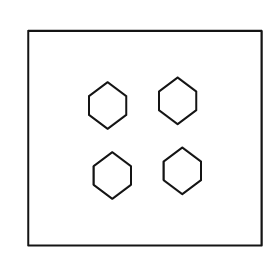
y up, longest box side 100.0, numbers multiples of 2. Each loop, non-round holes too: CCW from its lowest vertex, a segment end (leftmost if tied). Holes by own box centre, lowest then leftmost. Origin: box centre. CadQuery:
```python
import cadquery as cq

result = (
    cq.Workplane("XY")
    .moveTo(-50.0, -46.0)
    .lineTo(50.0, -46.0)
    .lineTo(50.0, 46.0)
    .lineTo(-50.0, 46.0)
    .close()
    .moveTo(-14.0, -26.0)
    .lineTo(-6.0, -20.0)
    .lineTo(-6.0, -12.0)
    .lineTo(-14.0, -6.0)
    .lineTo(-22.0, -12.0)
    .lineTo(-22.0, -20.0)
    .close()
    .moveTo(16.0, -24.0)
    .lineTo(24.0, -18.0)
    .lineTo(24.0, -10.0)
    .lineTo(16.0, -4.0)
    .lineTo(8.0, -10.0)
    .lineTo(8.0, -18.0)
    .close()
    .moveTo(-16.0, 4.0)
    .lineTo(-8.0, 10.0)
    .lineTo(-8.0, 18.0)
    .lineTo(-16.0, 24.0)
    .lineTo(-24.0, 18.0)
    .lineTo(-24.0, 10.0)
    .close()
    .moveTo(14.0, 6.0)
    .lineTo(22.0, 12.0)
    .lineTo(22.0, 20.0)
    .lineTo(14.0, 26.0)
    .lineTo(6.0, 20.0)
    .lineTo(6.0, 12.0)
    .close()
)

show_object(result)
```